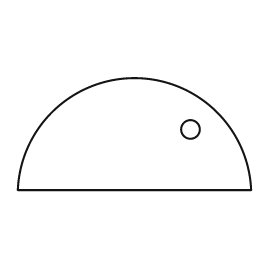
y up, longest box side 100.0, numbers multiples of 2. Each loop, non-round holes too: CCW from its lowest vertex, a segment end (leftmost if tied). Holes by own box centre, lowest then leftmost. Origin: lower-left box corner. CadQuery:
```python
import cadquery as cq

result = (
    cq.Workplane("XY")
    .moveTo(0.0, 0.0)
    .lineTo(100.0, 0.0)
    .threePointArc((50.0, 48.0), (0.0, 0.0))
    .close()
    .moveTo(74.0, 26.0)
    .circle(4.0)
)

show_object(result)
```